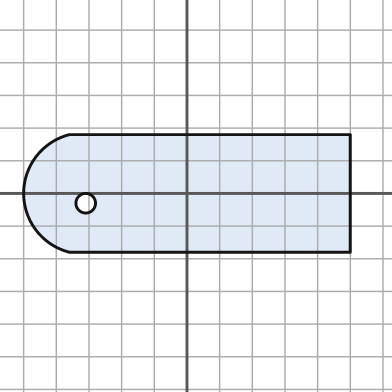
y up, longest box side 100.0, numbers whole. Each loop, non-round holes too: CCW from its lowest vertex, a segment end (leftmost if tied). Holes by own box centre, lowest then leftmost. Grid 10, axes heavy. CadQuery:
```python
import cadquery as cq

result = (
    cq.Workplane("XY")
    .moveTo(-36.0, -18.0)
    .lineTo(50.0, -18.0)
    .lineTo(50.0, 18.0)
    .lineTo(-36.0, 18.0)
    .threePointArc((-50.0, 0.0), (-36.0, -18.0))
    .close()
    .moveTo(-31.0, -3.0)
    .circle(3.0)
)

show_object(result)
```